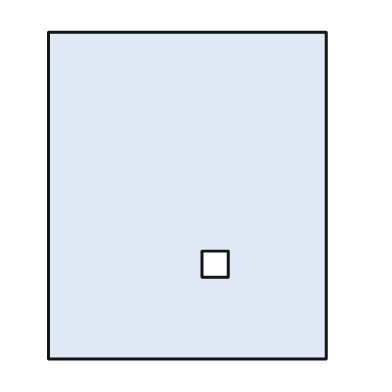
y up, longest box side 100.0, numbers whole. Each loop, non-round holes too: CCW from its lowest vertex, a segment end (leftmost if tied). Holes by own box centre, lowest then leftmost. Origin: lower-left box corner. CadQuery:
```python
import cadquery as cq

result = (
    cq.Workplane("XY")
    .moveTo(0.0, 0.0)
    .lineTo(85.0, 0.0)
    .lineTo(85.0, 100.0)
    .lineTo(0.0, 100.0)
    .close()
    .moveTo(47.0, 25.0)
    .lineTo(55.0, 25.0)
    .lineTo(55.0, 33.0)
    .lineTo(47.0, 33.0)
    .close()
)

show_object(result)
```